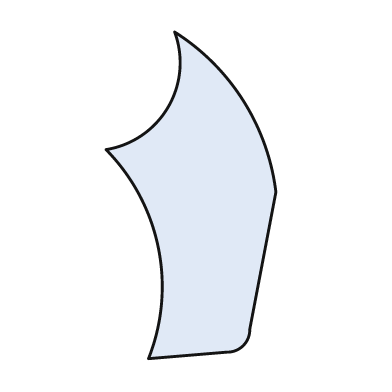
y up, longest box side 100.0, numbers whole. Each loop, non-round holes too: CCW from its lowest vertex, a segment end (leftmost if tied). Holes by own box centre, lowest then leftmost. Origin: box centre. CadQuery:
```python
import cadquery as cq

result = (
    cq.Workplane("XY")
    .moveTo(-13.0, -50.0)
    .lineTo(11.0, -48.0)
    .threePointArc((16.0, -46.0), (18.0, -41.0))
    .lineTo(26.0, 1.0)
    .threePointArc((16.0, 29.0), (-5.0, 50.0))
    .threePointArc((-7.0, 27.0), (-26.0, 14.0))
    .threePointArc((-10.0, -16.0), (-13.0, -50.0))
    .close()
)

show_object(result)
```